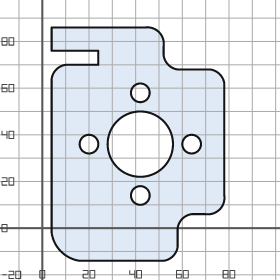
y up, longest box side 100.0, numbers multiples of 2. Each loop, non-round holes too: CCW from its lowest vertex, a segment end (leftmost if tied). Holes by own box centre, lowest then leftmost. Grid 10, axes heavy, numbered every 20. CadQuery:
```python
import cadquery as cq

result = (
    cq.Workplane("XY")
    .moveTo(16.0, -14.0)
    .lineTo(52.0, -14.0)
    .threePointArc((56.0, -12.0), (58.0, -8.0))
    .lineTo(58.0, 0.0)
    .threePointArc((60.0, 4.0), (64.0, 6.0))
    .lineTo(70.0, 6.0)
    .threePointArc((76.0, 8.0), (78.0, 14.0))
    .lineTo(78.0, 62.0)
    .threePointArc((76.0, 66.0), (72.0, 68.0))
    .lineTo(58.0, 68.0)
    .threePointArc((54.0, 70.0), (52.0, 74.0))
    .lineTo(52.0, 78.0)
    .threePointArc((50.0, 84.0), (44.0, 86.0))
    .lineTo(4.0, 86.0)
    .lineTo(4.0, 76.0)
    .lineTo(24.0, 76.0)
    .lineTo(24.0, 70.0)
    .lineTo(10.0, 70.0)
    .threePointArc((6.0, 68.0), (4.0, 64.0))
    .lineTo(4.0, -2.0)
    .threePointArc((8.0, -10.0), (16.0, -14.0))
    .close()
    .moveTo(42.0, 14.0)
    .circle(4.0)
    .moveTo(20.0, 36.0)
    .circle(4.0)
    .moveTo(42.0, 36.0)
    .circle(14.0)
    .moveTo(64.0, 36.0)
    .circle(4.0)
    .moveTo(42.0, 58.0)
    .circle(4.0)
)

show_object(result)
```